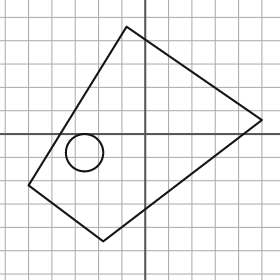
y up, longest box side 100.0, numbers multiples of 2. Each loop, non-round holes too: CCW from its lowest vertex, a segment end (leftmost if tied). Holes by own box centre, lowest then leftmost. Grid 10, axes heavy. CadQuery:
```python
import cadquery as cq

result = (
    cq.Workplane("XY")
    .moveTo(-18.0, -46.0)
    .lineTo(50.0, 6.0)
    .lineTo(-8.0, 46.0)
    .lineTo(-50.0, -22.0)
    .close()
    .moveTo(-26.0, -8.0)
    .circle(8.0)
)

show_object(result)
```